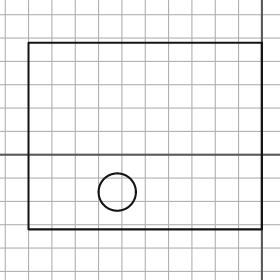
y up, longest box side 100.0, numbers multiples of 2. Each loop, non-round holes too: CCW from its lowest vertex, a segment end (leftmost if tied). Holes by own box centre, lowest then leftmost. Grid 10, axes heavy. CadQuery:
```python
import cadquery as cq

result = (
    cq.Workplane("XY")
    .moveTo(-100.0, -32.0)
    .lineTo(0.0, -32.0)
    .lineTo(0.0, 48.0)
    .lineTo(-100.0, 48.0)
    .close()
    .moveTo(-62.0, -16.0)
    .circle(8.0)
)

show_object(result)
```